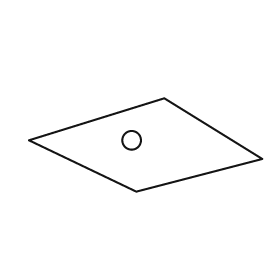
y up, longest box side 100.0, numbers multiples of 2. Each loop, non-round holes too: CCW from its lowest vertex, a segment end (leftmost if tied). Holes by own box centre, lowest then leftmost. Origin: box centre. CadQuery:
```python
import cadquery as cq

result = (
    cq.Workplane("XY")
    .moveTo(-4.0, -20.0)
    .lineTo(50.0, -6.0)
    .lineTo(8.0, 20.0)
    .lineTo(-50.0, 2.0)
    .close()
    .moveTo(-6.0, 2.0)
    .circle(4.0)
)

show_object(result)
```